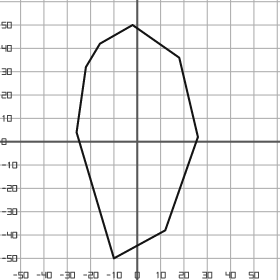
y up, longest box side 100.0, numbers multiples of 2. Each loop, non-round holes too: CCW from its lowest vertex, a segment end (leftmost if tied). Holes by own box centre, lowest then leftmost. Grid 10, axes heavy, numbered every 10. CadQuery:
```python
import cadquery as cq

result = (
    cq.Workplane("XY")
    .moveTo(-10.0, -50.0)
    .lineTo(12.0, -38.0)
    .lineTo(26.0, 2.0)
    .lineTo(18.0, 36.0)
    .lineTo(-2.0, 50.0)
    .lineTo(-16.0, 42.0)
    .lineTo(-22.0, 32.0)
    .lineTo(-26.0, 4.0)
    .close()
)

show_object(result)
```